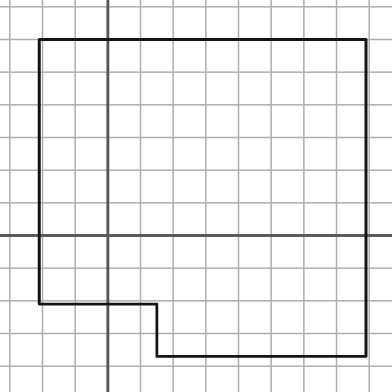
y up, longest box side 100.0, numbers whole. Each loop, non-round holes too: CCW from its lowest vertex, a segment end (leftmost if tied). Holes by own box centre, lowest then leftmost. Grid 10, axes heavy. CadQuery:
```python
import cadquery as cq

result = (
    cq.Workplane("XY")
    .moveTo(15.0, -37.0)
    .lineTo(79.0, -37.0)
    .lineTo(79.0, 60.0)
    .lineTo(-21.0, 60.0)
    .lineTo(-21.0, -21.0)
    .lineTo(15.0, -21.0)
    .close()
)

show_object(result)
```